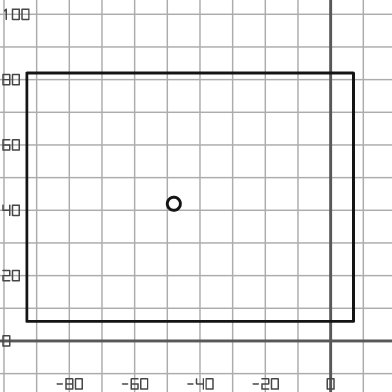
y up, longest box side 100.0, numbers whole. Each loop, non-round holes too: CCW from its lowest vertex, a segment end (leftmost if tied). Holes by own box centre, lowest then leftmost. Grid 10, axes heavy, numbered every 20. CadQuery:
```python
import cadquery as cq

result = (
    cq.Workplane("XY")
    .moveTo(-93.0, 6.0)
    .lineTo(7.0, 6.0)
    .lineTo(7.0, 82.0)
    .lineTo(-93.0, 82.0)
    .close()
    .moveTo(-48.0, 42.0)
    .circle(2.0)
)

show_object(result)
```